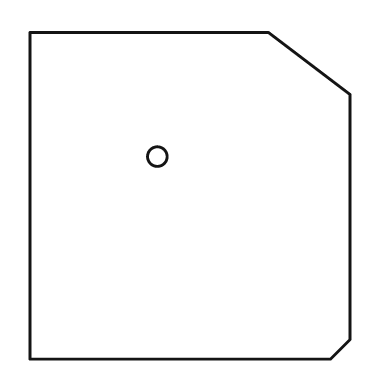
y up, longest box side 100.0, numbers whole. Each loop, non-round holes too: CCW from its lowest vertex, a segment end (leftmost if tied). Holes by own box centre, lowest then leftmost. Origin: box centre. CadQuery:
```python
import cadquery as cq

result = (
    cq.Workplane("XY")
    .moveTo(-49.0, -50.0)
    .lineTo(43.0, -50.0)
    .lineTo(49.0, -44.0)
    .lineTo(49.0, 31.0)
    .lineTo(24.0, 50.0)
    .lineTo(-49.0, 50.0)
    .close()
    .moveTo(-10.0, 12.0)
    .circle(3.0)
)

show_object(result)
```